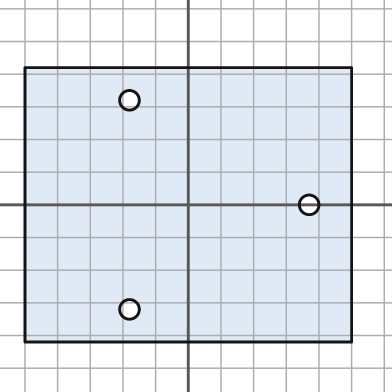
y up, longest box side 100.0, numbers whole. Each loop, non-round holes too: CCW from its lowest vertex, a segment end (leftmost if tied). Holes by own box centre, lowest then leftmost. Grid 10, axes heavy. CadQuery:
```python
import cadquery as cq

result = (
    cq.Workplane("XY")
    .moveTo(-50.0, -42.0)
    .lineTo(50.0, -42.0)
    .lineTo(50.0, 42.0)
    .lineTo(-50.0, 42.0)
    .close()
    .moveTo(-18.0, -32.0)
    .circle(3.0)
    .moveTo(37.0, 0.0)
    .circle(3.0)
    .moveTo(-18.0, 32.0)
    .circle(3.0)
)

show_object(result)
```